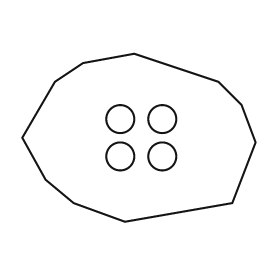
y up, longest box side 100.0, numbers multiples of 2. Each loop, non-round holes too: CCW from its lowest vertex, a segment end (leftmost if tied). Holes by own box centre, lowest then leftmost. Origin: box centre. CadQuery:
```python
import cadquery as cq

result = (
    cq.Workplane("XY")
    .moveTo(-6.0, -36.0)
    .lineTo(40.0, -28.0)
    .lineTo(50.0, -2.0)
    .lineTo(44.0, 14.0)
    .lineTo(34.0, 24.0)
    .lineTo(-2.0, 36.0)
    .lineTo(-24.0, 32.0)
    .lineTo(-36.0, 24.0)
    .lineTo(-50.0, 0.0)
    .lineTo(-40.0, -18.0)
    .lineTo(-28.0, -28.0)
    .close()
    .moveTo(-8.0, -8.0)
    .circle(6.0)
    .moveTo(10.0, -8.0)
    .circle(6.0)
    .moveTo(-8.0, 8.0)
    .circle(6.0)
    .moveTo(10.0, 8.0)
    .circle(6.0)
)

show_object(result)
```